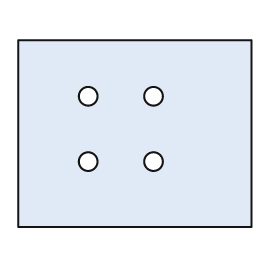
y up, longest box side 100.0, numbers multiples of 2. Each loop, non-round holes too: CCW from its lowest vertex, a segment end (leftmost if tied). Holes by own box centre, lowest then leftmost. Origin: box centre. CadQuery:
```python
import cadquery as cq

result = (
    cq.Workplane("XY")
    .moveTo(-50.0, -40.0)
    .lineTo(50.0, -40.0)
    .lineTo(50.0, 40.0)
    .lineTo(-50.0, 40.0)
    .close()
    .moveTo(-20.0, -12.0)
    .circle(4.0)
    .moveTo(8.0, -12.0)
    .circle(4.0)
    .moveTo(-20.0, 16.0)
    .circle(4.0)
    .moveTo(8.0, 16.0)
    .circle(4.0)
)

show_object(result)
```